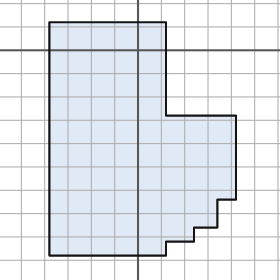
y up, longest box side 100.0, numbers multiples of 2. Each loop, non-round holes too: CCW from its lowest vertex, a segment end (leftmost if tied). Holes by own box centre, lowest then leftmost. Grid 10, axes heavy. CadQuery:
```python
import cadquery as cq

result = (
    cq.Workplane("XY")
    .moveTo(-38.0, -88.0)
    .lineTo(12.0, -88.0)
    .lineTo(12.0, -82.0)
    .lineTo(24.0, -82.0)
    .lineTo(24.0, -76.0)
    .lineTo(34.0, -76.0)
    .lineTo(34.0, -64.0)
    .lineTo(42.0, -64.0)
    .lineTo(42.0, -28.0)
    .lineTo(12.0, -28.0)
    .lineTo(12.0, 12.0)
    .lineTo(-38.0, 12.0)
    .close()
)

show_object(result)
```